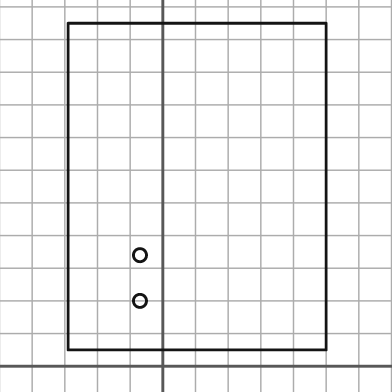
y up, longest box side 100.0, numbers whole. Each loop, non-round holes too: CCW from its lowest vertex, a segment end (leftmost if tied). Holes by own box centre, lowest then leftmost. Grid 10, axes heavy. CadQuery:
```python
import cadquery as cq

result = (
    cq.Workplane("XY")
    .moveTo(-29.0, 5.0)
    .lineTo(50.0, 5.0)
    .lineTo(50.0, 105.0)
    .lineTo(-29.0, 105.0)
    .close()
    .moveTo(-7.0, 20.0)
    .circle(2.0)
    .moveTo(-7.0, 34.0)
    .circle(2.0)
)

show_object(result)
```